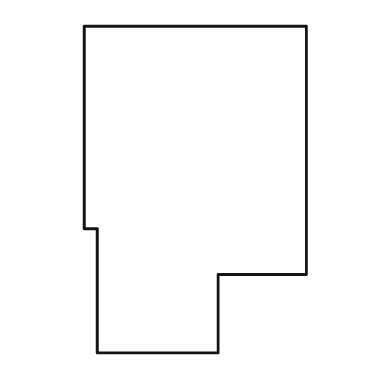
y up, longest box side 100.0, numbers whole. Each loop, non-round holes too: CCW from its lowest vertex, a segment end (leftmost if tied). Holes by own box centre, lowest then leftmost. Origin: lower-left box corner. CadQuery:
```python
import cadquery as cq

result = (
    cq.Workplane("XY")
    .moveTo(4.0, 0.0)
    .lineTo(41.0, 0.0)
    .lineTo(41.0, 24.0)
    .lineTo(68.0, 24.0)
    .lineTo(68.0, 100.0)
    .lineTo(0.0, 100.0)
    .lineTo(0.0, 38.0)
    .lineTo(4.0, 38.0)
    .close()
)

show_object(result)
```